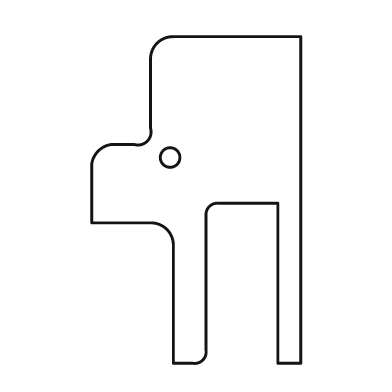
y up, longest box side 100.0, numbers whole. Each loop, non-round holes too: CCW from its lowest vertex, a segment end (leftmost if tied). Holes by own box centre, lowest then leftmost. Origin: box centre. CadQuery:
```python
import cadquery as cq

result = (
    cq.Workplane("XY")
    .moveTo(-7.0, -50.0)
    .lineTo(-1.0, -50.0)
    .threePointArc((2.0, -49.0), (3.0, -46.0))
    .lineTo(3.0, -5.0)
    .threePointArc((4.0, -2.0), (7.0, -1.0))
    .lineTo(25.0, -1.0)
    .lineTo(25.0, -50.0)
    .lineTo(32.0, -50.0)
    .lineTo(32.0, 50.0)
    .lineTo(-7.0, 50.0)
    .threePointArc((-12.0, 48.0), (-14.0, 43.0))
    .lineTo(-14.0, 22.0)
    .threePointArc((-15.0, 18.0), (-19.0, 17.0))
    .lineTo(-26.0, 17.0)
    .threePointArc((-30.0, 15.0), (-32.0, 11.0))
    .lineTo(-32.0, -7.0)
    .lineTo(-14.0, -7.0)
    .threePointArc((-9.0, -9.0), (-7.0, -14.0))
    .close()
    .moveTo(-8.0, 13.0)
    .circle(3.0)
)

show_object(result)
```